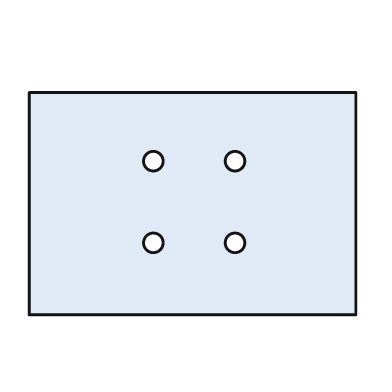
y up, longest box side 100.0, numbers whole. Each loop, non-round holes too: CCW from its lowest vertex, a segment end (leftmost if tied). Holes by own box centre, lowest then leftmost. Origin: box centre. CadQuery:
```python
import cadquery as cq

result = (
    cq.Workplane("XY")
    .moveTo(-50.0, -34.0)
    .lineTo(50.0, -34.0)
    .lineTo(50.0, 34.0)
    .lineTo(-50.0, 34.0)
    .close()
    .moveTo(-12.0, -12.0)
    .circle(3.0)
    .moveTo(13.0, -12.0)
    .circle(3.0)
    .moveTo(-12.0, 13.0)
    .circle(3.0)
    .moveTo(13.0, 13.0)
    .circle(3.0)
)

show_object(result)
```